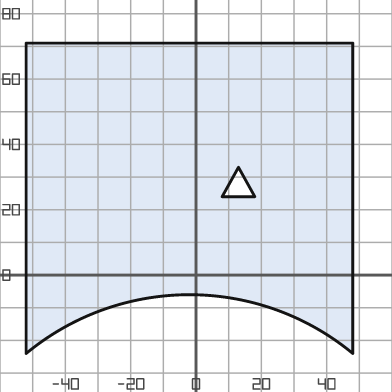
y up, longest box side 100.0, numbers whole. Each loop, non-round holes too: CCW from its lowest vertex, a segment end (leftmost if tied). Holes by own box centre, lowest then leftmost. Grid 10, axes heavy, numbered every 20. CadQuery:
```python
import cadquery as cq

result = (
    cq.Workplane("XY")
    .moveTo(-52.0, -24.0)
    .threePointArc((-2.0, -6.0), (48.0, -24.0))
    .lineTo(48.0, 71.0)
    .lineTo(-52.0, 71.0)
    .close()
    .moveTo(8.0, 24.0)
    .lineTo(18.0, 24.0)
    .lineTo(13.0, 33.0)
    .close()
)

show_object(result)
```